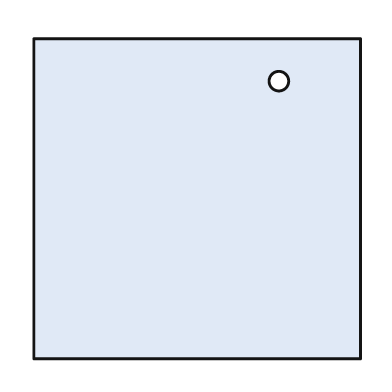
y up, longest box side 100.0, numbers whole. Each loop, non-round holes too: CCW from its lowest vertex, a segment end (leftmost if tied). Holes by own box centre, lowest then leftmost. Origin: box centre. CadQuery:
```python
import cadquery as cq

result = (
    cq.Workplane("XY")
    .moveTo(-50.0, -49.0)
    .lineTo(50.0, -49.0)
    .lineTo(50.0, 49.0)
    .lineTo(-50.0, 49.0)
    .close()
    .moveTo(25.0, 36.0)
    .circle(3.0)
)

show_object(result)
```